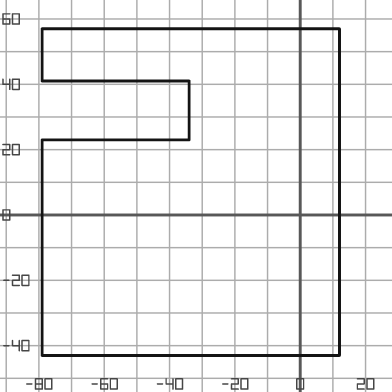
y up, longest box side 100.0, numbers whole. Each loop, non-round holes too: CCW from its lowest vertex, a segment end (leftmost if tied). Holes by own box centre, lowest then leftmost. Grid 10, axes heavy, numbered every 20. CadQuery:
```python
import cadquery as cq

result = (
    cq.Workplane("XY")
    .moveTo(-79.0, -43.0)
    .lineTo(12.0, -43.0)
    .lineTo(12.0, 57.0)
    .lineTo(-79.0, 57.0)
    .lineTo(-79.0, 41.0)
    .lineTo(-34.0, 41.0)
    .lineTo(-34.0, 23.0)
    .lineTo(-79.0, 23.0)
    .close()
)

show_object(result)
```